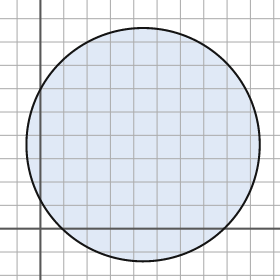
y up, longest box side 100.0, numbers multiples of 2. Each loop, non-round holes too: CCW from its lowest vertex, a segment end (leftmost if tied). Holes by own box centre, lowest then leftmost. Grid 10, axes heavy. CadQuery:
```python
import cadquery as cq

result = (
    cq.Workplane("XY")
    .moveTo(44.0, 36.0)
    .circle(50.0)
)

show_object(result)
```